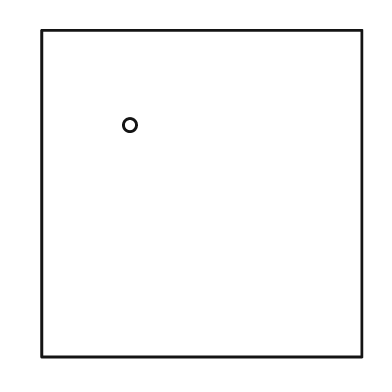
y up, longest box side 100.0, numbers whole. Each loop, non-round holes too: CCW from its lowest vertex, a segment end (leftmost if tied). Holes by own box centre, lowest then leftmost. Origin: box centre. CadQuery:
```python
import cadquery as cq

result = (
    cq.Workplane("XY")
    .moveTo(-49.0, -50.0)
    .lineTo(49.0, -50.0)
    .lineTo(49.0, 50.0)
    .lineTo(-49.0, 50.0)
    .close()
    .moveTo(-22.0, 21.0)
    .circle(2.0)
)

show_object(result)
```